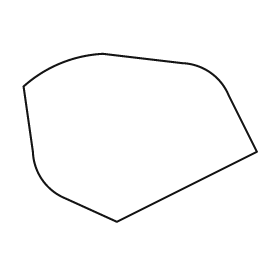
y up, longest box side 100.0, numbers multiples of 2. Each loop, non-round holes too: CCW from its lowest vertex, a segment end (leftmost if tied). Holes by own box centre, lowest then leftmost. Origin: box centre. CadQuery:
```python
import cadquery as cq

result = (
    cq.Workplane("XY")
    .moveTo(-10.0, -36.0)
    .lineTo(50.0, -6.0)
    .lineTo(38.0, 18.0)
    .threePointArc((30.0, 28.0), (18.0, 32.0))
    .lineTo(-16.0, 36.0)
    .threePointArc((-34.0, 32.0), (-50.0, 22.0))
    .lineTo(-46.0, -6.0)
    .threePointArc((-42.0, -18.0), (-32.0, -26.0))
    .close()
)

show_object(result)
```